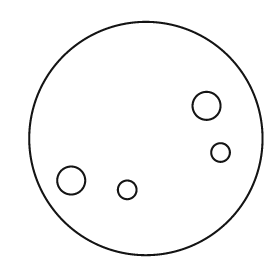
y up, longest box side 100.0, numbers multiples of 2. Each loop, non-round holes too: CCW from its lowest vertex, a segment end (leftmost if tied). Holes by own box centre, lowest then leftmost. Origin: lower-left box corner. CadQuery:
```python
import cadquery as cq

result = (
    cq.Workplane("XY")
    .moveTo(50.0, 50.0)
    .circle(50.0)
    .moveTo(42.0, 28.0)
    .circle(4.0)
    .moveTo(18.0, 32.0)
    .circle(6.0)
    .moveTo(82.0, 44.0)
    .circle(4.0)
    .moveTo(76.0, 64.0)
    .circle(6.0)
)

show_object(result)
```